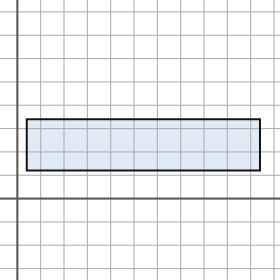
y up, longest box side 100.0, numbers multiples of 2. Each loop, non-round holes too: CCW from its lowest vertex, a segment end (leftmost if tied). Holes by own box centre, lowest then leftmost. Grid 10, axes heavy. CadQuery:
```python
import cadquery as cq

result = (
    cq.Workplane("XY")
    .moveTo(4.0, 12.0)
    .lineTo(104.0, 12.0)
    .lineTo(104.0, 34.0)
    .lineTo(4.0, 34.0)
    .close()
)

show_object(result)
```